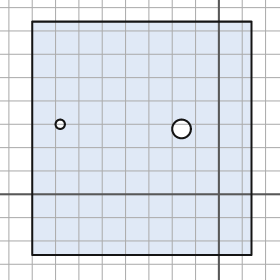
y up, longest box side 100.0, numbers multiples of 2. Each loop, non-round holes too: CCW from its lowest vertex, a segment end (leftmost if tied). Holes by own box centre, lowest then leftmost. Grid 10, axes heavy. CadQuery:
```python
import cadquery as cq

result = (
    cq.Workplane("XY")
    .moveTo(-80.0, -26.0)
    .lineTo(14.0, -26.0)
    .lineTo(14.0, 74.0)
    .lineTo(-80.0, 74.0)
    .close()
    .moveTo(-16.0, 28.0)
    .circle(4.0)
    .moveTo(-68.0, 30.0)
    .circle(2.0)
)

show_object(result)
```